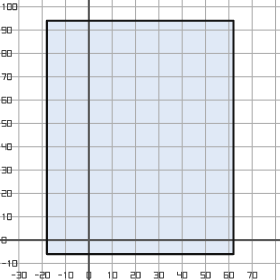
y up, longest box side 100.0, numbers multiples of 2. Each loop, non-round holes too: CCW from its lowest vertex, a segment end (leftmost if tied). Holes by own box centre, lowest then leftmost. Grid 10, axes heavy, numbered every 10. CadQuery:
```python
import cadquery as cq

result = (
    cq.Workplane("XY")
    .moveTo(-18.0, -6.0)
    .lineTo(62.0, -6.0)
    .lineTo(62.0, 94.0)
    .lineTo(-18.0, 94.0)
    .close()
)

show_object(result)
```